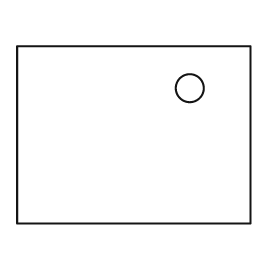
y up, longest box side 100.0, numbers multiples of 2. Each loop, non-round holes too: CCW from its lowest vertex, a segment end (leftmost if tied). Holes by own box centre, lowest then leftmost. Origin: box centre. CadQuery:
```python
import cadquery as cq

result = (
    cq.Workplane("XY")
    .moveTo(-50.0, -38.0)
    .lineTo(50.0, -38.0)
    .lineTo(50.0, 38.0)
    .lineTo(-50.0, 38.0)
    .close()
    .moveTo(24.0, 20.0)
    .circle(6.0)
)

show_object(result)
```